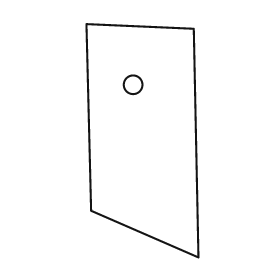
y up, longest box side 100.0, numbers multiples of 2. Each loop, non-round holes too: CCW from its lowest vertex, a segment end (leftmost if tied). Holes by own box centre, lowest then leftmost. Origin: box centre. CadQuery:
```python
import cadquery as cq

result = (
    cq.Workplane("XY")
    .moveTo(24.0, -50.0)
    .lineTo(22.0, 48.0)
    .lineTo(-24.0, 50.0)
    .lineTo(-22.0, -30.0)
    .close()
    .moveTo(-4.0, 24.0)
    .circle(4.0)
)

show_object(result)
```